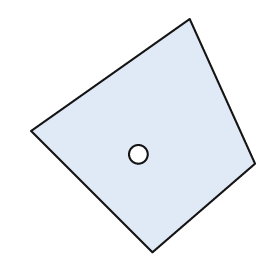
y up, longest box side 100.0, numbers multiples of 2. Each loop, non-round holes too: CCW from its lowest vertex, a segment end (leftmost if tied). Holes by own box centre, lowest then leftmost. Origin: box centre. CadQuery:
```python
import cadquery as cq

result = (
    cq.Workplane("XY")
    .moveTo(4.0, -50.0)
    .lineTo(48.0, -12.0)
    .lineTo(20.0, 50.0)
    .lineTo(-48.0, 2.0)
    .close()
    .moveTo(-2.0, -8.0)
    .circle(4.0)
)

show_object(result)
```